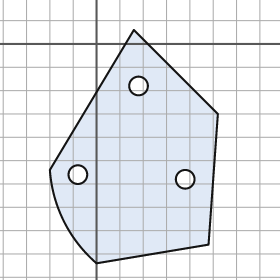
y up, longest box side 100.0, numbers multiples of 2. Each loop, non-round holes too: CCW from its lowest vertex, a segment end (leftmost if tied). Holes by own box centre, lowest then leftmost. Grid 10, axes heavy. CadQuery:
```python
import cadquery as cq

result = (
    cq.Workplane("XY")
    .moveTo(0.0, -94.0)
    .lineTo(48.0, -86.0)
    .lineTo(52.0, -30.0)
    .lineTo(16.0, 6.0)
    .lineTo(-20.0, -54.0)
    .threePointArc((-14.0, -76.0), (0.0, -94.0))
    .close()
    .moveTo(38.0, -58.0)
    .circle(4.0)
    .moveTo(-8.0, -56.0)
    .circle(4.0)
    .moveTo(18.0, -18.0)
    .circle(4.0)
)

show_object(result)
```